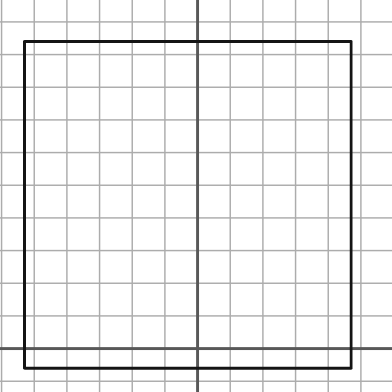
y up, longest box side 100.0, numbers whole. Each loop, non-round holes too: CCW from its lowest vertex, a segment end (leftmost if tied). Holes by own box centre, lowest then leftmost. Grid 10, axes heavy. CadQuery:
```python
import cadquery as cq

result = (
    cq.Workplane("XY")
    .moveTo(-53.0, -6.0)
    .lineTo(47.0, -6.0)
    .lineTo(47.0, 94.0)
    .lineTo(-53.0, 94.0)
    .close()
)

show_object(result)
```